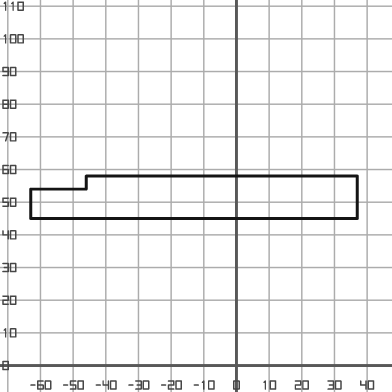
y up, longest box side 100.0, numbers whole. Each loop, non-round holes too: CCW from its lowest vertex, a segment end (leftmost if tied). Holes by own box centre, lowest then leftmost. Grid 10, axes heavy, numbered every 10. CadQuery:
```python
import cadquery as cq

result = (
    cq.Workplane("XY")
    .moveTo(-63.0, 45.0)
    .lineTo(37.0, 45.0)
    .lineTo(37.0, 58.0)
    .lineTo(-46.0, 58.0)
    .lineTo(-46.0, 54.0)
    .lineTo(-63.0, 54.0)
    .close()
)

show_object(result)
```